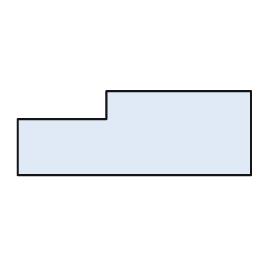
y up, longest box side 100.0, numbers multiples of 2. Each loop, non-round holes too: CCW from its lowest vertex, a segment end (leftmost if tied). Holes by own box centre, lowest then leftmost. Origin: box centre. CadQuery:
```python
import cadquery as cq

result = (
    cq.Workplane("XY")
    .moveTo(-50.0, -18.0)
    .lineTo(50.0, -18.0)
    .lineTo(50.0, 18.0)
    .lineTo(-12.0, 18.0)
    .lineTo(-12.0, 6.0)
    .lineTo(-50.0, 6.0)
    .close()
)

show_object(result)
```